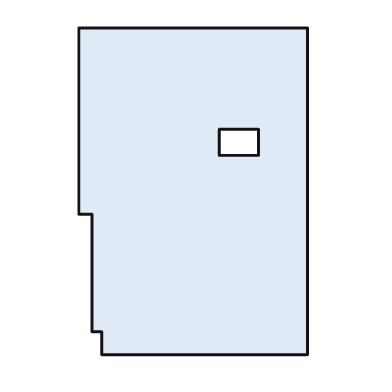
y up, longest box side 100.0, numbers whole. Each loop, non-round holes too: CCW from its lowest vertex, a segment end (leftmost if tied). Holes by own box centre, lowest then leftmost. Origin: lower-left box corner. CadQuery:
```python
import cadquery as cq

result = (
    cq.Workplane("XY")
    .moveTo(7.0, 0.0)
    .lineTo(70.0, 0.0)
    .lineTo(70.0, 100.0)
    .lineTo(0.0, 100.0)
    .lineTo(0.0, 43.0)
    .lineTo(4.0, 43.0)
    .lineTo(4.0, 7.0)
    .lineTo(7.0, 7.0)
    .close()
    .moveTo(43.0, 61.0)
    .lineTo(55.0, 61.0)
    .lineTo(55.0, 69.0)
    .lineTo(43.0, 69.0)
    .close()
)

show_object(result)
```